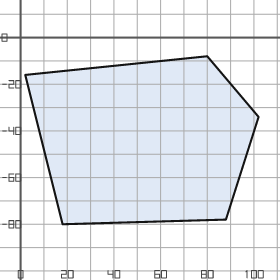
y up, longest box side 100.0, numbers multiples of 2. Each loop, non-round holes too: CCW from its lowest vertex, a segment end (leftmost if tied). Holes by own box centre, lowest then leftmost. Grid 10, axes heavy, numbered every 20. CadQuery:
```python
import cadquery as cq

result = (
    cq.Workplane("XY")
    .moveTo(18.0, -80.0)
    .lineTo(88.0, -78.0)
    .lineTo(102.0, -34.0)
    .lineTo(80.0, -8.0)
    .lineTo(2.0, -16.0)
    .close()
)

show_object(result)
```